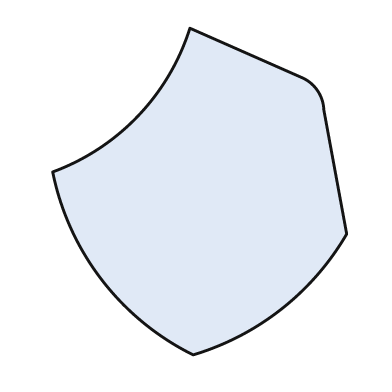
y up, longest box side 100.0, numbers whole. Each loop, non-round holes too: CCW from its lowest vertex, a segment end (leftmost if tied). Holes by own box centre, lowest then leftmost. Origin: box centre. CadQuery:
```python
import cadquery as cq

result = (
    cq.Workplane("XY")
    .moveTo(-2.0, -50.0)
    .threePointArc((25.0, -36.0), (45.0, -13.0))
    .lineTo(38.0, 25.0)
    .threePointArc((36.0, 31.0), (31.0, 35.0))
    .lineTo(-3.0, 50.0)
    .threePointArc((-19.0, 23.0), (-45.0, 6.0))
    .threePointArc((-30.0, -27.0), (-2.0, -50.0))
    .close()
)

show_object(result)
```